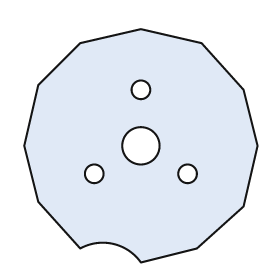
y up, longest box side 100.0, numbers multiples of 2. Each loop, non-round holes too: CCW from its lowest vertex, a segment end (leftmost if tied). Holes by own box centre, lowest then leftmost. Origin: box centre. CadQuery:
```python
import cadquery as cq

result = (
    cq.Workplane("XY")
    .moveTo(0.0, -50.0)
    .lineTo(24.0, -44.0)
    .lineTo(44.0, -26.0)
    .lineTo(50.0, 0.0)
    .lineTo(44.0, 24.0)
    .lineTo(26.0, 44.0)
    .lineTo(0.0, 50.0)
    .lineTo(-26.0, 44.0)
    .lineTo(-44.0, 26.0)
    .lineTo(-50.0, 0.0)
    .lineTo(-44.0, -24.0)
    .lineTo(-26.0, -44.0)
    .threePointArc((-12.0, -42.0), (0.0, -50.0))
    .close()
    .moveTo(-20.0, -12.0)
    .circle(4.0)
    .moveTo(20.0, -12.0)
    .circle(4.0)
    .moveTo(0.0, 0.0)
    .circle(8.0)
    .moveTo(0.0, 24.0)
    .circle(4.0)
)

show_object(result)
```